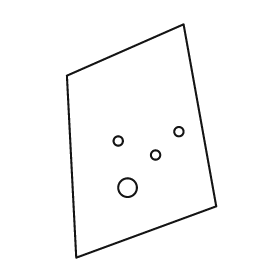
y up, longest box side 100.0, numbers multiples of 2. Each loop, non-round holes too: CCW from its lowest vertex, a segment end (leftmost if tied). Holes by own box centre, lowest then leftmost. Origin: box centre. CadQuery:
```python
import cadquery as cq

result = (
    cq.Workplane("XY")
    .moveTo(-28.0, -50.0)
    .lineTo(32.0, -28.0)
    .lineTo(18.0, 50.0)
    .lineTo(-32.0, 28.0)
    .close()
    .moveTo(-6.0, -20.0)
    .circle(4.0)
    .moveTo(6.0, -6.0)
    .circle(2.0)
    .moveTo(-10.0, 0.0)
    .circle(2.0)
    .moveTo(16.0, 4.0)
    .circle(2.0)
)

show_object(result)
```